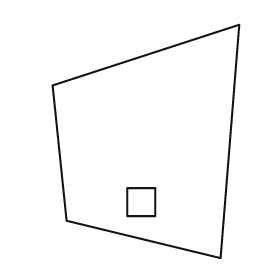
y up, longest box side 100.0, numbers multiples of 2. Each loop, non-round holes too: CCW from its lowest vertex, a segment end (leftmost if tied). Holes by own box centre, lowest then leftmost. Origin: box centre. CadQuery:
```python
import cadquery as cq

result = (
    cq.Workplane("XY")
    .moveTo(32.0, -50.0)
    .lineTo(40.0, 50.0)
    .lineTo(-40.0, 24.0)
    .lineTo(-34.0, -34.0)
    .close()
    .moveTo(-8.0, -32.0)
    .lineTo(4.0, -32.0)
    .lineTo(4.0, -20.0)
    .lineTo(-8.0, -20.0)
    .close()
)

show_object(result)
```